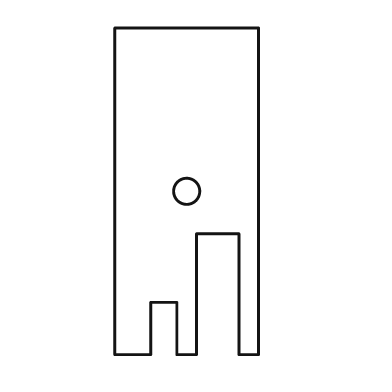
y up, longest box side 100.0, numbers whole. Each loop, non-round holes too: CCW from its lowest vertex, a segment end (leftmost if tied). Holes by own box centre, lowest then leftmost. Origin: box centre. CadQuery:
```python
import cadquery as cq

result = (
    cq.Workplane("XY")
    .moveTo(-22.0, -50.0)
    .lineTo(-11.0, -50.0)
    .lineTo(-11.0, -34.0)
    .lineTo(-3.0, -34.0)
    .lineTo(-3.0, -50.0)
    .lineTo(3.0, -50.0)
    .lineTo(3.0, -13.0)
    .lineTo(16.0, -13.0)
    .lineTo(16.0, -50.0)
    .lineTo(22.0, -50.0)
    .lineTo(22.0, 50.0)
    .lineTo(-22.0, 50.0)
    .close()
    .moveTo(0.0, 0.0)
    .circle(4.0)
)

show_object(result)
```